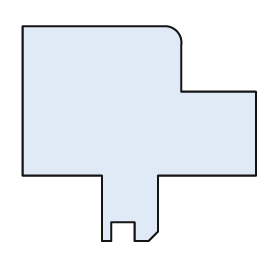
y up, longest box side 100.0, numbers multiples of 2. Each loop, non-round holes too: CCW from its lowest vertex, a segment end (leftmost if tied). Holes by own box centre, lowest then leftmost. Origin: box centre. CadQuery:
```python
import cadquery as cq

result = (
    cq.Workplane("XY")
    .moveTo(-16.0, -46.0)
    .lineTo(-12.0, -46.0)
    .lineTo(-12.0, -38.0)
    .lineTo(-2.0, -38.0)
    .lineTo(-2.0, -46.0)
    .lineTo(4.0, -46.0)
    .lineTo(8.0, -42.0)
    .lineTo(8.0, -18.0)
    .lineTo(50.0, -18.0)
    .lineTo(50.0, 18.0)
    .lineTo(18.0, 18.0)
    .lineTo(18.0, 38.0)
    .threePointArc((16.0, 44.0), (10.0, 46.0))
    .lineTo(-50.0, 46.0)
    .lineTo(-50.0, -18.0)
    .lineTo(-16.0, -18.0)
    .close()
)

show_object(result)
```